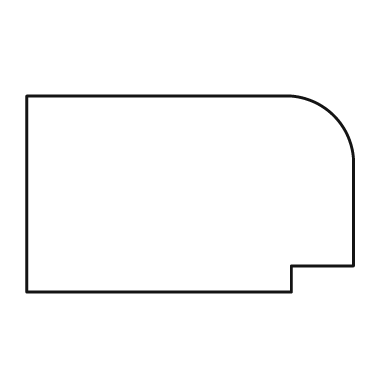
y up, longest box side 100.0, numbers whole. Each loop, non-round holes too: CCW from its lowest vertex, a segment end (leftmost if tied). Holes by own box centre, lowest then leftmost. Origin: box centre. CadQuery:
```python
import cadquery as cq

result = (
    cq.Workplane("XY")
    .moveTo(-50.0, -30.0)
    .lineTo(31.0, -30.0)
    .lineTo(31.0, -22.0)
    .lineTo(50.0, -22.0)
    .lineTo(50.0, 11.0)
    .threePointArc((44.0, 24.0), (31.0, 30.0))
    .lineTo(-50.0, 30.0)
    .close()
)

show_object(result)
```